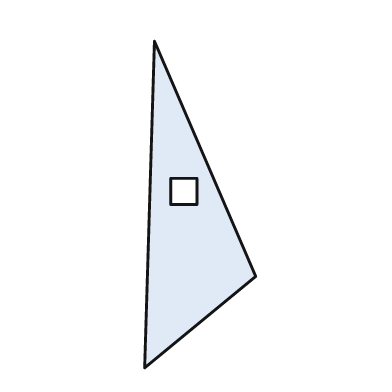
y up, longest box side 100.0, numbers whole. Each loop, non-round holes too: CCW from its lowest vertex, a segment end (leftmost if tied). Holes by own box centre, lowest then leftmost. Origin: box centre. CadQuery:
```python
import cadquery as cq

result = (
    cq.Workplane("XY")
    .moveTo(-17.0, -50.0)
    .lineTo(17.0, -22.0)
    .lineTo(-14.0, 50.0)
    .close()
    .moveTo(-9.0, 0.0)
    .lineTo(-1.0, 0.0)
    .lineTo(-1.0, 8.0)
    .lineTo(-9.0, 8.0)
    .close()
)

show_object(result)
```